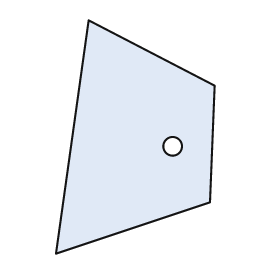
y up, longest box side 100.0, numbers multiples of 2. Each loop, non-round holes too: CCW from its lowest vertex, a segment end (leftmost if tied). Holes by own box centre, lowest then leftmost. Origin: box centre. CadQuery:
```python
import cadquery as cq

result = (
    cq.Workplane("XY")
    .moveTo(-34.0, -50.0)
    .lineTo(32.0, -28.0)
    .lineTo(34.0, 22.0)
    .lineTo(-20.0, 50.0)
    .close()
    .moveTo(16.0, -4.0)
    .circle(4.0)
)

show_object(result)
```